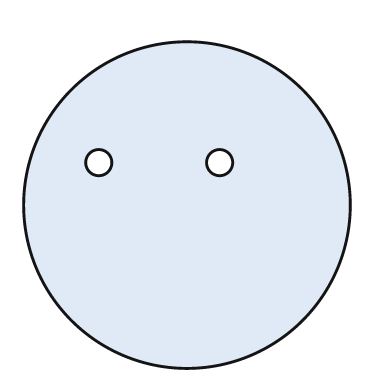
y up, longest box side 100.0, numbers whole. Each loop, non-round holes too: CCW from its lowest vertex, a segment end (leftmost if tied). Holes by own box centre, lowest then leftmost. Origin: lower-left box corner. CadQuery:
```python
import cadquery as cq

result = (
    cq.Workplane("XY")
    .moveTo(50.0, 50.0)
    .circle(50.0)
    .moveTo(23.0, 63.0)
    .circle(4.0)
    .moveTo(60.0, 63.0)
    .circle(4.0)
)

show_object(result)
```